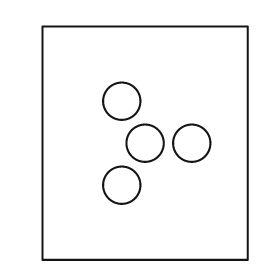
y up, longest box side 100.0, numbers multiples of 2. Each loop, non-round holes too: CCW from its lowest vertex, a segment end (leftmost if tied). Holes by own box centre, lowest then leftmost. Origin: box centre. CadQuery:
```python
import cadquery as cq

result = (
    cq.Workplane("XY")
    .moveTo(-44.0, -50.0)
    .lineTo(44.0, -50.0)
    .lineTo(44.0, 50.0)
    .lineTo(-44.0, 50.0)
    .close()
    .moveTo(-10.0, -18.0)
    .circle(8.0)
    .moveTo(0.0, 0.0)
    .circle(8.0)
    .moveTo(20.0, 0.0)
    .circle(8.0)
    .moveTo(-10.0, 18.0)
    .circle(8.0)
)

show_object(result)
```